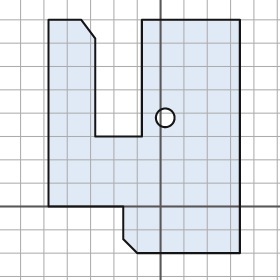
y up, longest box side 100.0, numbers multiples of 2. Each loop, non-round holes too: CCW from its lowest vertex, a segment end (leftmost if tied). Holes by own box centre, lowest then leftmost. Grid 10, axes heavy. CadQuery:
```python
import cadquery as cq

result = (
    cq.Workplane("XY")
    .moveTo(-10.0, -20.0)
    .lineTo(34.0, -20.0)
    .lineTo(34.0, 80.0)
    .lineTo(-8.0, 80.0)
    .lineTo(-8.0, 30.0)
    .lineTo(-28.0, 30.0)
    .lineTo(-28.0, 72.0)
    .lineTo(-34.0, 80.0)
    .lineTo(-48.0, 80.0)
    .lineTo(-48.0, 0.0)
    .lineTo(-16.0, 0.0)
    .lineTo(-16.0, -14.0)
    .close()
    .moveTo(2.0, 38.0)
    .circle(4.0)
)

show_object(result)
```